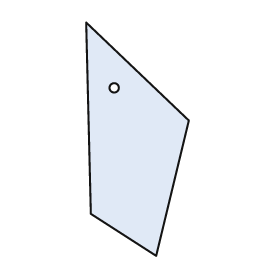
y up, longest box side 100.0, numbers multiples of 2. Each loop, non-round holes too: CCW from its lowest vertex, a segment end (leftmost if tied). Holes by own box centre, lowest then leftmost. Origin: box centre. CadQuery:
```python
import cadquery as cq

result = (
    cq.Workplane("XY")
    .moveTo(8.0, -50.0)
    .lineTo(22.0, 8.0)
    .lineTo(-22.0, 50.0)
    .lineTo(-20.0, -32.0)
    .close()
    .moveTo(-10.0, 22.0)
    .circle(2.0)
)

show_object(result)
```